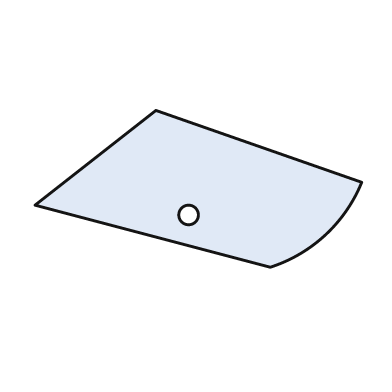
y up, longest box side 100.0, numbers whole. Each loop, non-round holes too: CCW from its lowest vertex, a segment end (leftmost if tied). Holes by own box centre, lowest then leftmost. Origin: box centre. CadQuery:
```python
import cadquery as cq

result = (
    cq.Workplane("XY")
    .moveTo(22.0, -24.0)
    .threePointArc((39.0, -14.0), (50.0, 2.0))
    .lineTo(-13.0, 24.0)
    .lineTo(-50.0, -5.0)
    .close()
    .moveTo(-3.0, -8.0)
    .circle(3.0)
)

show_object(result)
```